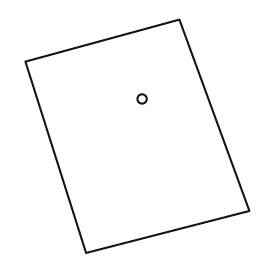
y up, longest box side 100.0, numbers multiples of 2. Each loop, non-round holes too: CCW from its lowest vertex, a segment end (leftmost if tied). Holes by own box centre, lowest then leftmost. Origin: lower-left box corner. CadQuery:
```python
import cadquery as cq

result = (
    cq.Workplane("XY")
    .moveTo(26.0, 0.0)
    .lineTo(96.0, 18.0)
    .lineTo(66.0, 100.0)
    .lineTo(0.0, 82.0)
    .close()
    .moveTo(50.0, 66.0)
    .circle(2.0)
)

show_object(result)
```